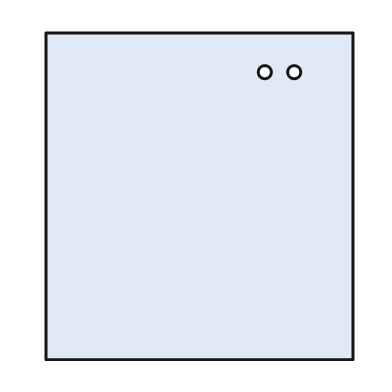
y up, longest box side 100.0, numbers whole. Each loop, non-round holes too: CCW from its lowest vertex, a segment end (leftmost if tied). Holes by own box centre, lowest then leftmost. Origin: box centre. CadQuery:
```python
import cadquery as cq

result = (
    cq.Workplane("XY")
    .moveTo(-47.0, -50.0)
    .lineTo(47.0, -50.0)
    .lineTo(47.0, 50.0)
    .lineTo(-47.0, 50.0)
    .close()
    .moveTo(20.0, 38.0)
    .circle(2.0)
    .moveTo(29.0, 38.0)
    .circle(2.0)
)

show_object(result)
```